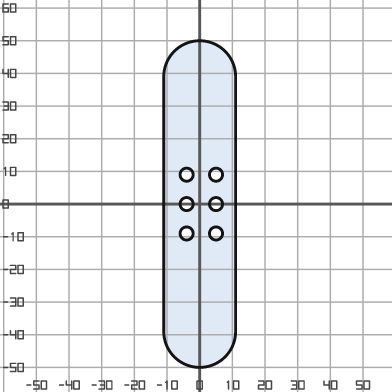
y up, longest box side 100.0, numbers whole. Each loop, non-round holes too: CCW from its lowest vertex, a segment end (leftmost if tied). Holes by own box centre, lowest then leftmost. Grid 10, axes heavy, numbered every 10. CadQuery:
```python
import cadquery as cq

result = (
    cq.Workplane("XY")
    .moveTo(-11.0, -39.0)
    .threePointArc((0.0, -50.0), (11.0, -39.0))
    .lineTo(11.0, 39.0)
    .threePointArc((0.0, 50.0), (-11.0, 39.0))
    .close()
    .moveTo(-4.0, -9.0)
    .circle(2.0)
    .moveTo(5.0, -9.0)
    .circle(2.0)
    .moveTo(-4.0, 0.0)
    .circle(2.0)
    .moveTo(5.0, 0.0)
    .circle(2.0)
    .moveTo(-4.0, 9.0)
    .circle(2.0)
    .moveTo(5.0, 9.0)
    .circle(2.0)
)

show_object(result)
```